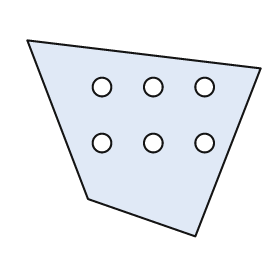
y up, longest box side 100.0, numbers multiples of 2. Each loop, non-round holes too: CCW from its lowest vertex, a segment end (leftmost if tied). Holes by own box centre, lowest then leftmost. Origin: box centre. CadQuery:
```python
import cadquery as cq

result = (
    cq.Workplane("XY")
    .moveTo(22.0, -42.0)
    .lineTo(50.0, 30.0)
    .lineTo(-50.0, 42.0)
    .lineTo(-24.0, -26.0)
    .close()
    .moveTo(-18.0, -2.0)
    .circle(4.0)
    .moveTo(4.0, -2.0)
    .circle(4.0)
    .moveTo(26.0, -2.0)
    .circle(4.0)
    .moveTo(-18.0, 22.0)
    .circle(4.0)
    .moveTo(4.0, 22.0)
    .circle(4.0)
    .moveTo(26.0, 22.0)
    .circle(4.0)
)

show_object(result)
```